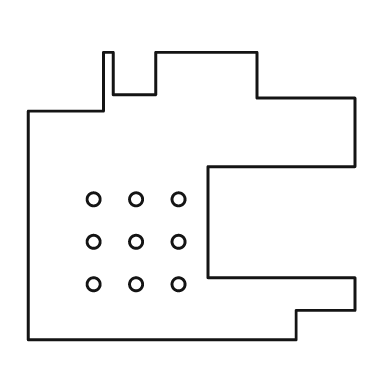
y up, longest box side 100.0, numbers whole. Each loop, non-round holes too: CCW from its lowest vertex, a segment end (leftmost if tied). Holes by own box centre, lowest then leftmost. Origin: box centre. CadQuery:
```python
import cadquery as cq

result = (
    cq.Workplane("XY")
    .moveTo(-50.0, -44.0)
    .lineTo(32.0, -44.0)
    .lineTo(32.0, -35.0)
    .lineTo(50.0, -35.0)
    .lineTo(50.0, -25.0)
    .lineTo(5.0, -25.0)
    .lineTo(5.0, 9.0)
    .lineTo(50.0, 9.0)
    .lineTo(50.0, 30.0)
    .lineTo(20.0, 30.0)
    .lineTo(20.0, 44.0)
    .lineTo(-11.0, 44.0)
    .lineTo(-11.0, 31.0)
    .lineTo(-24.0, 31.0)
    .lineTo(-24.0, 44.0)
    .lineTo(-27.0, 44.0)
    .lineTo(-27.0, 26.0)
    .lineTo(-50.0, 26.0)
    .close()
    .moveTo(-30.0, -27.0)
    .circle(2.0)
    .moveTo(-17.0, -27.0)
    .circle(2.0)
    .moveTo(-4.0, -27.0)
    .circle(2.0)
    .moveTo(-30.0, -14.0)
    .circle(2.0)
    .moveTo(-17.0, -14.0)
    .circle(2.0)
    .moveTo(-4.0, -14.0)
    .circle(2.0)
    .moveTo(-30.0, -1.0)
    .circle(2.0)
    .moveTo(-17.0, -1.0)
    .circle(2.0)
    .moveTo(-4.0, -1.0)
    .circle(2.0)
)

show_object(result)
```